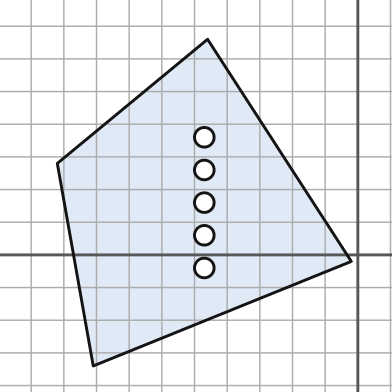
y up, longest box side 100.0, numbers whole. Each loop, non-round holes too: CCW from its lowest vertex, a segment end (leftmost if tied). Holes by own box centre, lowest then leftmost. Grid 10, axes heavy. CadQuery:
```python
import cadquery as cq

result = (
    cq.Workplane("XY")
    .moveTo(-81.0, -34.0)
    .lineTo(-2.0, -2.0)
    .lineTo(-46.0, 66.0)
    .lineTo(-92.0, 28.0)
    .close()
    .moveTo(-47.0, -4.0)
    .circle(3.0)
    .moveTo(-47.0, 6.0)
    .circle(3.0)
    .moveTo(-47.0, 16.0)
    .circle(3.0)
    .moveTo(-47.0, 26.0)
    .circle(3.0)
    .moveTo(-47.0, 36.0)
    .circle(3.0)
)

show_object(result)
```